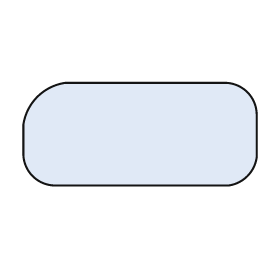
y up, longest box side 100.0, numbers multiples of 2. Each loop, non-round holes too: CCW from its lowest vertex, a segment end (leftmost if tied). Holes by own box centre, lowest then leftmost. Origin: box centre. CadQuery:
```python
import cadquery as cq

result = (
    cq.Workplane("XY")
    .moveTo(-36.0, -22.0)
    .lineTo(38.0, -22.0)
    .threePointArc((46.0, -18.0), (50.0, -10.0))
    .lineTo(50.0, 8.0)
    .threePointArc((46.0, 18.0), (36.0, 22.0))
    .lineTo(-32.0, 22.0)
    .threePointArc((-44.0, 16.0), (-50.0, 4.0))
    .lineTo(-50.0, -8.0)
    .threePointArc((-46.0, -18.0), (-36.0, -22.0))
    .close()
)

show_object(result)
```